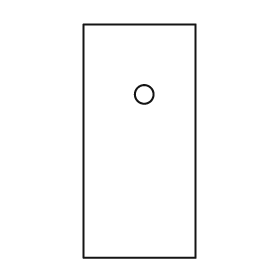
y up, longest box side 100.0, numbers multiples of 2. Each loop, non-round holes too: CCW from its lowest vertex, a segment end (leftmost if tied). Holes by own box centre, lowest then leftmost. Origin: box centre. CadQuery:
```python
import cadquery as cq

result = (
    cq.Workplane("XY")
    .moveTo(-24.0, -50.0)
    .lineTo(24.0, -50.0)
    .lineTo(24.0, 50.0)
    .lineTo(-24.0, 50.0)
    .close()
    .moveTo(2.0, 20.0)
    .circle(4.0)
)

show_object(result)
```